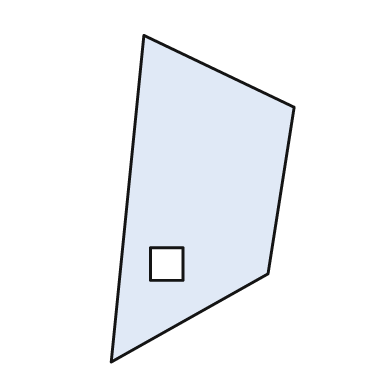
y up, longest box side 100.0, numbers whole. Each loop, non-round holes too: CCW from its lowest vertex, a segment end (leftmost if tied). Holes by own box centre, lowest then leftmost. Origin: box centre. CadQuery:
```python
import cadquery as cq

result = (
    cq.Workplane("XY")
    .moveTo(-28.0, -50.0)
    .lineTo(20.0, -23.0)
    .lineTo(28.0, 28.0)
    .lineTo(-18.0, 50.0)
    .close()
    .moveTo(-16.0, -25.0)
    .lineTo(-6.0, -25.0)
    .lineTo(-6.0, -15.0)
    .lineTo(-16.0, -15.0)
    .close()
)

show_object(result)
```